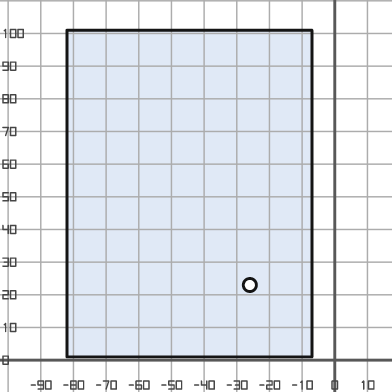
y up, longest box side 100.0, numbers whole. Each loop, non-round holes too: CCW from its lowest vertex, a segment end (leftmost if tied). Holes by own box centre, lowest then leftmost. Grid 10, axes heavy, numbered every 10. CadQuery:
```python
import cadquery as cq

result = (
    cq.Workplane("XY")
    .moveTo(-82.0, 1.0)
    .lineTo(-7.0, 1.0)
    .lineTo(-7.0, 101.0)
    .lineTo(-82.0, 101.0)
    .close()
    .moveTo(-26.0, 23.0)
    .circle(2.0)
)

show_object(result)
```